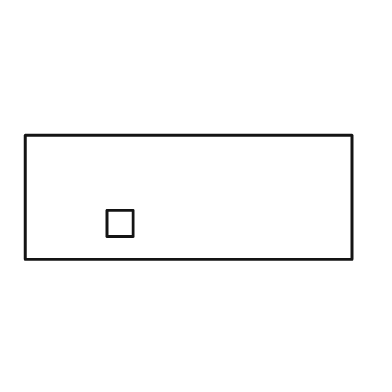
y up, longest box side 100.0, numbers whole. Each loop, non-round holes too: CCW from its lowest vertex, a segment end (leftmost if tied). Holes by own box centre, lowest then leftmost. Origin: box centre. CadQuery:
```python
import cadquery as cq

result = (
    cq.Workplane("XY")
    .moveTo(-50.0, -19.0)
    .lineTo(50.0, -19.0)
    .lineTo(50.0, 19.0)
    .lineTo(-50.0, 19.0)
    .close()
    .moveTo(-25.0, -12.0)
    .lineTo(-17.0, -12.0)
    .lineTo(-17.0, -4.0)
    .lineTo(-25.0, -4.0)
    .close()
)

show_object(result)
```